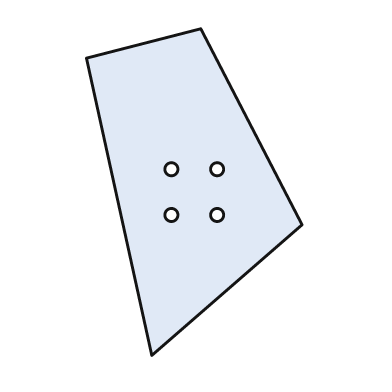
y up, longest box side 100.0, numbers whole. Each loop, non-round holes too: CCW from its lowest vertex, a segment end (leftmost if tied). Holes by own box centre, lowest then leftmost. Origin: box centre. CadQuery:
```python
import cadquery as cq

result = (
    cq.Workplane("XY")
    .moveTo(-13.0, -50.0)
    .lineTo(33.0, -10.0)
    .lineTo(2.0, 50.0)
    .lineTo(-33.0, 41.0)
    .close()
    .moveTo(-7.0, -7.0)
    .circle(2.0)
    .moveTo(7.0, -7.0)
    .circle(2.0)
    .moveTo(-7.0, 7.0)
    .circle(2.0)
    .moveTo(7.0, 7.0)
    .circle(2.0)
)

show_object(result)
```